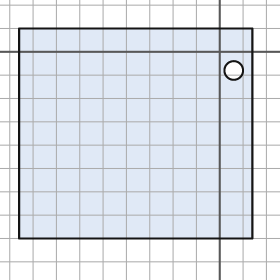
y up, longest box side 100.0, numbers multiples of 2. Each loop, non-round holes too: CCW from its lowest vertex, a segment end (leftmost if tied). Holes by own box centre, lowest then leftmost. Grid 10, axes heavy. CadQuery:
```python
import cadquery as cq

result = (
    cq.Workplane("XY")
    .moveTo(-86.0, -80.0)
    .lineTo(14.0, -80.0)
    .lineTo(14.0, 10.0)
    .lineTo(-86.0, 10.0)
    .close()
    .moveTo(6.0, -8.0)
    .circle(4.0)
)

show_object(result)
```